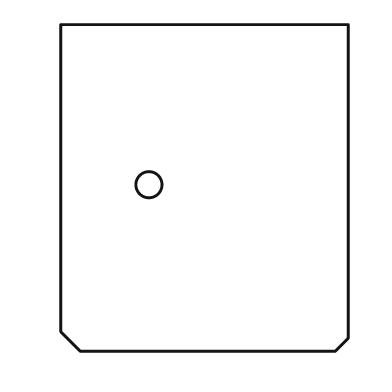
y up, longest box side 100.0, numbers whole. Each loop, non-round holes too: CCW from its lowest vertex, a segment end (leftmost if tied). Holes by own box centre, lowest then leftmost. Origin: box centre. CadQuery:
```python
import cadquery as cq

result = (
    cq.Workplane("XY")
    .moveTo(-38.0, -50.0)
    .lineTo(40.0, -50.0)
    .lineTo(44.0, -46.0)
    .lineTo(44.0, 50.0)
    .lineTo(-44.0, 50.0)
    .lineTo(-44.0, -44.0)
    .close()
    .moveTo(-17.0, 1.0)
    .circle(4.0)
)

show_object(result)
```